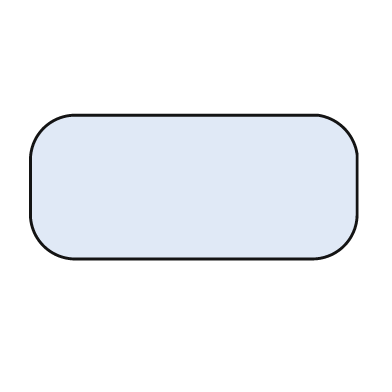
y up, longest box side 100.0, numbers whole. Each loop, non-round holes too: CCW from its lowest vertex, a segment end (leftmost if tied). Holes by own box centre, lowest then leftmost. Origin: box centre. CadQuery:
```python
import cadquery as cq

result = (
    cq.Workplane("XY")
    .moveTo(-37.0, -22.0)
    .lineTo(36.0, -22.0)
    .threePointArc((46.0, -18.0), (50.0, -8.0))
    .lineTo(50.0, 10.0)
    .threePointArc((46.0, 18.0), (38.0, 22.0))
    .lineTo(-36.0, 22.0)
    .threePointArc((-46.0, 18.0), (-50.0, 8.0))
    .lineTo(-50.0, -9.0)
    .threePointArc((-46.0, -18.0), (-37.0, -22.0))
    .close()
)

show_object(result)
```